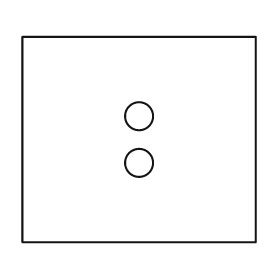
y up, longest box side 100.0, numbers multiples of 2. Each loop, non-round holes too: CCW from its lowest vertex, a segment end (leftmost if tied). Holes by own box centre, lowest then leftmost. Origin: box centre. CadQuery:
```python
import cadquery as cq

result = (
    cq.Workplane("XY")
    .moveTo(-50.0, -44.0)
    .lineTo(50.0, -44.0)
    .lineTo(50.0, 44.0)
    .lineTo(-50.0, 44.0)
    .close()
    .moveTo(0.0, -10.0)
    .circle(6.0)
    .moveTo(0.0, 10.0)
    .circle(6.0)
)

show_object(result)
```